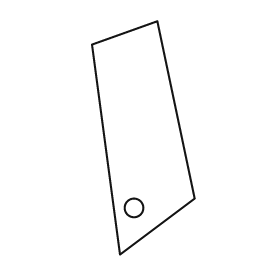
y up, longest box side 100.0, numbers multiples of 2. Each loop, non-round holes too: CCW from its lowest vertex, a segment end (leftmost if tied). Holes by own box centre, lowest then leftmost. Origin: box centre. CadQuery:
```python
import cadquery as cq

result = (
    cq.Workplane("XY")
    .moveTo(-10.0, -50.0)
    .lineTo(22.0, -26.0)
    .lineTo(6.0, 50.0)
    .lineTo(-22.0, 40.0)
    .close()
    .moveTo(-4.0, -30.0)
    .circle(4.0)
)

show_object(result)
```